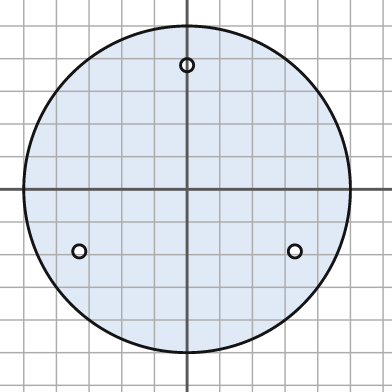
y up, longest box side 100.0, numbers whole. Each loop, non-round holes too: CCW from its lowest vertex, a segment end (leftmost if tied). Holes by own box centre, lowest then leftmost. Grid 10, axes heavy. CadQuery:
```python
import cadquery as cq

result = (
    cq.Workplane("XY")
    .moveTo(0.0, 0.0)
    .circle(50.0)
    .moveTo(-33.0, -19.0)
    .circle(2.0)
    .moveTo(33.0, -19.0)
    .circle(2.0)
    .moveTo(0.0, 38.0)
    .circle(2.0)
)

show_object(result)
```